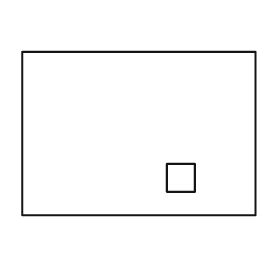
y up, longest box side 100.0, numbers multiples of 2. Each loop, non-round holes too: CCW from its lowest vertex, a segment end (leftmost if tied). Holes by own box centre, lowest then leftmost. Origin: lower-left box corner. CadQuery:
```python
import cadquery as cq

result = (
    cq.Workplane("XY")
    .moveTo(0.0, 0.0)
    .lineTo(100.0, 0.0)
    .lineTo(100.0, 70.0)
    .lineTo(0.0, 70.0)
    .close()
    .moveTo(62.0, 10.0)
    .lineTo(74.0, 10.0)
    .lineTo(74.0, 22.0)
    .lineTo(62.0, 22.0)
    .close()
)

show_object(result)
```